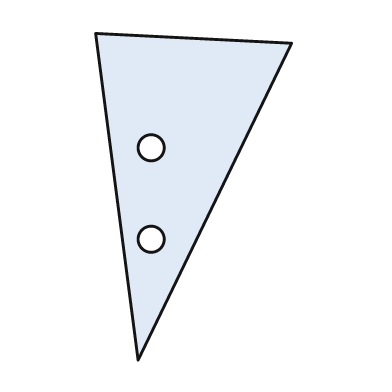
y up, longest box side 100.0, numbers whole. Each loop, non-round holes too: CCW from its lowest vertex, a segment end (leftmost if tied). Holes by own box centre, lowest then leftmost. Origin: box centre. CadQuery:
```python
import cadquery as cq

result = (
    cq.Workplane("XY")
    .moveTo(-17.0, -50.0)
    .lineTo(30.0, 47.0)
    .lineTo(-30.0, 50.0)
    .close()
    .moveTo(-13.0, -13.0)
    .circle(4.0)
    .moveTo(-13.0, 15.0)
    .circle(4.0)
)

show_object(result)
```